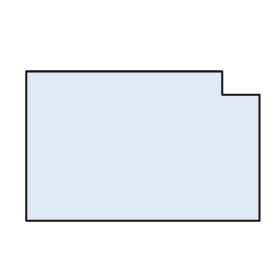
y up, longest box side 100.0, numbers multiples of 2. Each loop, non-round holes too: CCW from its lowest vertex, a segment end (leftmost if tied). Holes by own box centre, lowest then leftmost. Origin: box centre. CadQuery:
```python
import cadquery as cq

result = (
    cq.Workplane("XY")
    .moveTo(-50.0, -32.0)
    .lineTo(50.0, -32.0)
    .lineTo(50.0, 22.0)
    .lineTo(34.0, 22.0)
    .lineTo(34.0, 32.0)
    .lineTo(-50.0, 32.0)
    .close()
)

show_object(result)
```